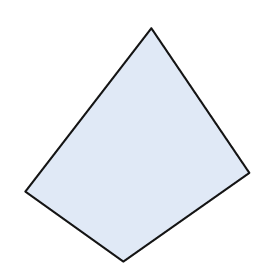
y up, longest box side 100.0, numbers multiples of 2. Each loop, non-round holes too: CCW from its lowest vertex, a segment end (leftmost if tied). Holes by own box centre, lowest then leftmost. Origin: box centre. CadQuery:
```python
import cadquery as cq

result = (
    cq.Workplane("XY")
    .moveTo(-6.0, -50.0)
    .lineTo(48.0, -12.0)
    .lineTo(6.0, 50.0)
    .lineTo(-48.0, -20.0)
    .close()
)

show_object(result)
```